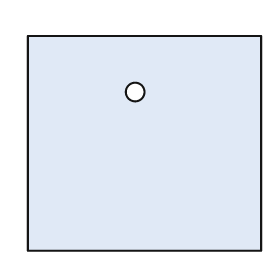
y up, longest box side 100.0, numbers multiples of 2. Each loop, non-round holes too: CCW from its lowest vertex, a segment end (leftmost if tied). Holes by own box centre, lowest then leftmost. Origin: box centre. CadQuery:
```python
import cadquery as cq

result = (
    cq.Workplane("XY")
    .moveTo(-50.0, -46.0)
    .lineTo(50.0, -46.0)
    .lineTo(50.0, 46.0)
    .lineTo(-50.0, 46.0)
    .close()
    .moveTo(-4.0, 22.0)
    .circle(4.0)
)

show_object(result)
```